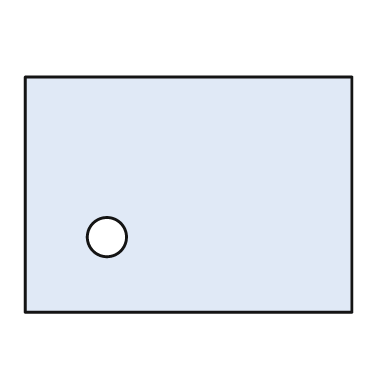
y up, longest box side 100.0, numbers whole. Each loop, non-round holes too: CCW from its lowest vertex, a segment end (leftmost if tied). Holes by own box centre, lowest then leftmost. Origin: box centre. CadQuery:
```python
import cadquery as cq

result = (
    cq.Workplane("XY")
    .moveTo(-50.0, -36.0)
    .lineTo(50.0, -36.0)
    .lineTo(50.0, 36.0)
    .lineTo(-50.0, 36.0)
    .close()
    .moveTo(-25.0, -13.0)
    .circle(6.0)
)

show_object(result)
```